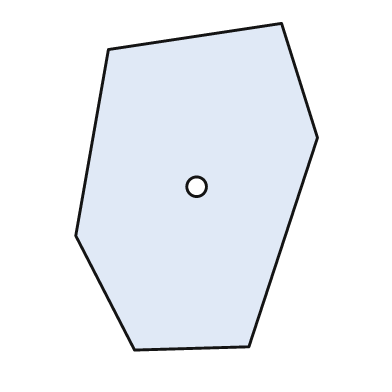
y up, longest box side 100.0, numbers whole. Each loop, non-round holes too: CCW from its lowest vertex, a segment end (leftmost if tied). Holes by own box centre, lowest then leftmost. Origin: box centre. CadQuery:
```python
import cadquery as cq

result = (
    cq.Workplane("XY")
    .moveTo(-19.0, -50.0)
    .lineTo(16.0, -49.0)
    .lineTo(37.0, 15.0)
    .lineTo(26.0, 50.0)
    .lineTo(-27.0, 42.0)
    .lineTo(-37.0, -15.0)
    .close()
    .moveTo(0.0, 0.0)
    .circle(3.0)
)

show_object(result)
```